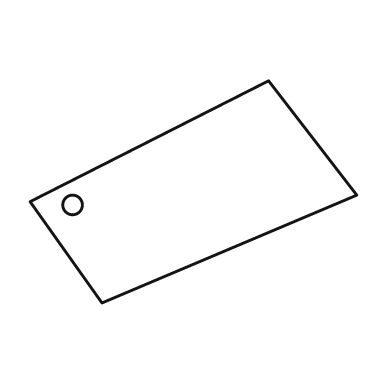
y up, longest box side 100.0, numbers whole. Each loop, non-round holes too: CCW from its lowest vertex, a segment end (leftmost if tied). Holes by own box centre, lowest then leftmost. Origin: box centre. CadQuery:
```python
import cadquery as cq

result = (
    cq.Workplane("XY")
    .moveTo(-28.0, -34.0)
    .lineTo(50.0, -1.0)
    .lineTo(23.0, 34.0)
    .lineTo(-50.0, -3.0)
    .close()
    .moveTo(-37.0, -4.0)
    .circle(3.0)
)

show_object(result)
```